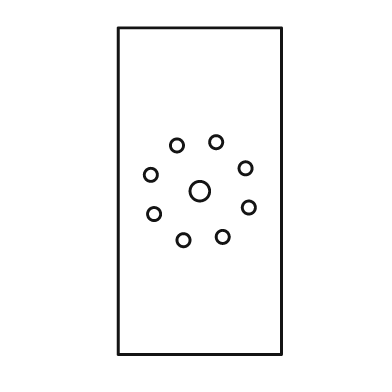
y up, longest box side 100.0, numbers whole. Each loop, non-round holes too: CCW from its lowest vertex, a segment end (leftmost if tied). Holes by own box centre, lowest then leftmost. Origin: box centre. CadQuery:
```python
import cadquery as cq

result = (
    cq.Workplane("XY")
    .moveTo(-25.0, -50.0)
    .lineTo(25.0, -50.0)
    .lineTo(25.0, 50.0)
    .lineTo(-25.0, 50.0)
    .close()
    .moveTo(-5.0, -15.0)
    .circle(2.0)
    .moveTo(7.0, -14.0)
    .circle(2.0)
    .moveTo(-14.0, -7.0)
    .circle(2.0)
    .moveTo(15.0, -5.0)
    .circle(2.0)
    .moveTo(0.0, 0.0)
    .circle(3.0)
    .moveTo(-15.0, 5.0)
    .circle(2.0)
    .moveTo(14.0, 7.0)
    .circle(2.0)
    .moveTo(-7.0, 14.0)
    .circle(2.0)
    .moveTo(5.0, 15.0)
    .circle(2.0)
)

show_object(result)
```